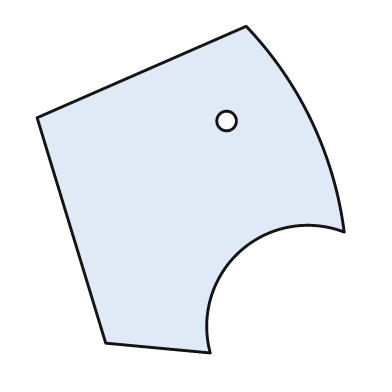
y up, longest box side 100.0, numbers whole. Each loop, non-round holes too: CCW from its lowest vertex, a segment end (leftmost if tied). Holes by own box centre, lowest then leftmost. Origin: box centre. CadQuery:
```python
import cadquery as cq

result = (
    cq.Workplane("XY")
    .moveTo(6.0, -50.0)
    .threePointArc((15.0, -19.0), (47.0, -13.0))
    .threePointArc((37.0, 21.0), (17.0, 50.0))
    .lineTo(-47.0, 22.0)
    .lineTo(-26.0, -47.0)
    .close()
    .moveTo(11.0, 21.0)
    .circle(3.0)
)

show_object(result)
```